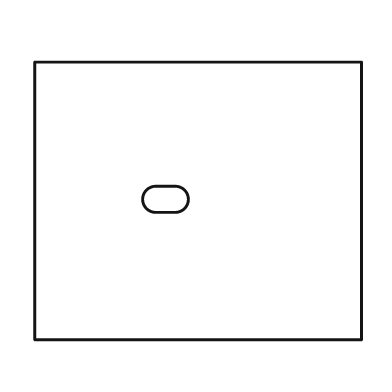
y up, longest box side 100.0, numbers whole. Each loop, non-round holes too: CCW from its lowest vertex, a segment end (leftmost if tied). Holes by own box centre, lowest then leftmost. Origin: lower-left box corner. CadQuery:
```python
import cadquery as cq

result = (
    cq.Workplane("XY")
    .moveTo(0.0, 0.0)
    .lineTo(100.0, 0.0)
    .lineTo(100.0, 85.0)
    .lineTo(0.0, 85.0)
    .close()
    .moveTo(37.0, 39.0)
    .lineTo(43.0, 39.0)
    .threePointArc((47.0, 43.0), (43.0, 47.0))
    .lineTo(37.0, 47.0)
    .threePointArc((33.0, 43.0), (37.0, 39.0))
    .close()
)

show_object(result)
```